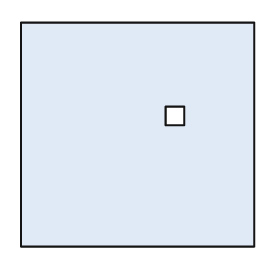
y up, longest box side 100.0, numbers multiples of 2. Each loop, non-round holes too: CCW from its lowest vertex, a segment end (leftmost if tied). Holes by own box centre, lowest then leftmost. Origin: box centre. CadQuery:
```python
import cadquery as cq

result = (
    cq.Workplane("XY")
    .moveTo(-50.0, -48.0)
    .lineTo(50.0, -48.0)
    .lineTo(50.0, 48.0)
    .lineTo(-50.0, 48.0)
    .close()
    .moveTo(12.0, 4.0)
    .lineTo(20.0, 4.0)
    .lineTo(20.0, 12.0)
    .lineTo(12.0, 12.0)
    .close()
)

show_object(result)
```